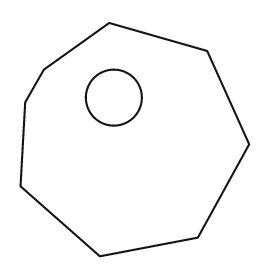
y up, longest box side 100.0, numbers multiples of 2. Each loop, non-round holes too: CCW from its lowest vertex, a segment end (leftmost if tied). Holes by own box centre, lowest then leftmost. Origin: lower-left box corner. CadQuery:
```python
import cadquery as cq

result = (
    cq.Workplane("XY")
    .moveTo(34.0, 0.0)
    .lineTo(76.0, 8.0)
    .lineTo(98.0, 48.0)
    .lineTo(80.0, 88.0)
    .lineTo(38.0, 100.0)
    .lineTo(10.0, 80.0)
    .lineTo(2.0, 66.0)
    .lineTo(0.0, 30.0)
    .close()
    .moveTo(40.0, 68.0)
    .circle(12.0)
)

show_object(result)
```